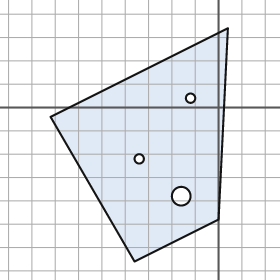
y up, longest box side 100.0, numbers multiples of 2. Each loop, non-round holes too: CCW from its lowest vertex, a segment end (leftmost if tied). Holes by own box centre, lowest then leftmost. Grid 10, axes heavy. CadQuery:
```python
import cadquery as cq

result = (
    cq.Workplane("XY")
    .moveTo(-36.0, -66.0)
    .lineTo(0.0, -48.0)
    .lineTo(4.0, 34.0)
    .lineTo(-72.0, -4.0)
    .close()
    .moveTo(-16.0, -38.0)
    .circle(4.0)
    .moveTo(-34.0, -22.0)
    .circle(2.0)
    .moveTo(-12.0, 4.0)
    .circle(2.0)
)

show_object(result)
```